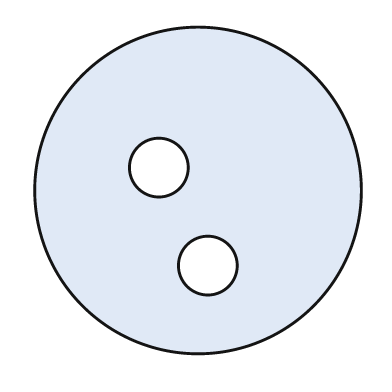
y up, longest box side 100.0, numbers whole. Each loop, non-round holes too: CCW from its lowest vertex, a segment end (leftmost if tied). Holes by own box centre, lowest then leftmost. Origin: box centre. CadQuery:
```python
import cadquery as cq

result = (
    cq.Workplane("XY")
    .moveTo(0.0, 0.0)
    .circle(50.0)
    .moveTo(3.0, -23.0)
    .circle(9.0)
    .moveTo(-12.0, 7.0)
    .circle(9.0)
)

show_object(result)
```